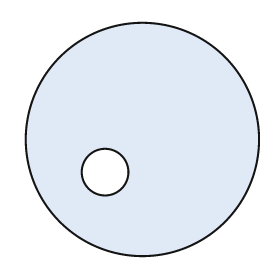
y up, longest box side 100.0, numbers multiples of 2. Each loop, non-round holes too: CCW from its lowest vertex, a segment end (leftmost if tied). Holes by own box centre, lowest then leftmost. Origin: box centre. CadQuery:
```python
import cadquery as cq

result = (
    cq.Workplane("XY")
    .moveTo(0.0, 0.0)
    .circle(50.0)
    .moveTo(-16.0, -14.0)
    .circle(10.0)
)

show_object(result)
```